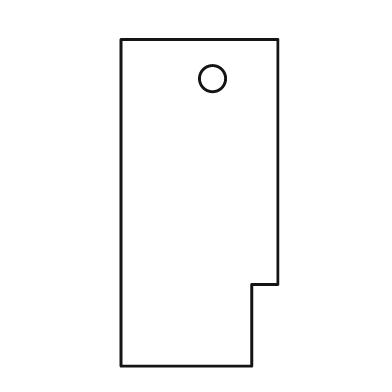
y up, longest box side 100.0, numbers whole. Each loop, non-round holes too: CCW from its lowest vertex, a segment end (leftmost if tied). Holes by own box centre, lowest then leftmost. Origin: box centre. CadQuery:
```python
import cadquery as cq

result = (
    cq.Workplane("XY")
    .moveTo(-24.0, -50.0)
    .lineTo(16.0, -50.0)
    .lineTo(16.0, -25.0)
    .lineTo(24.0, -25.0)
    .lineTo(24.0, 50.0)
    .lineTo(-24.0, 50.0)
    .close()
    .moveTo(4.0, 38.0)
    .circle(4.0)
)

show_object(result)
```